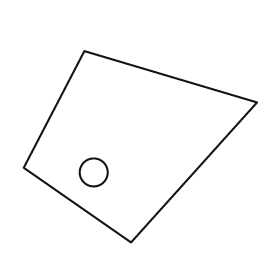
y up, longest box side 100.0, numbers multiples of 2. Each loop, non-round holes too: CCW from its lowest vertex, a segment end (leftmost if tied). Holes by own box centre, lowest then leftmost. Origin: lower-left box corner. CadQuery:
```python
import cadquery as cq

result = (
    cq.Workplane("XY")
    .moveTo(46.0, 0.0)
    .lineTo(100.0, 60.0)
    .lineTo(26.0, 82.0)
    .lineTo(0.0, 32.0)
    .close()
    .moveTo(30.0, 30.0)
    .circle(6.0)
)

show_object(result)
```